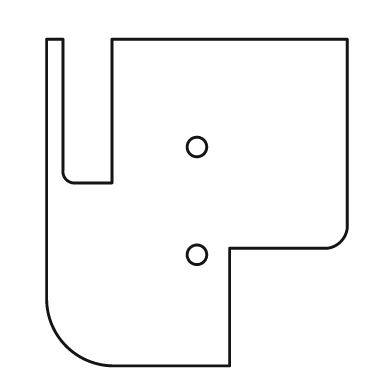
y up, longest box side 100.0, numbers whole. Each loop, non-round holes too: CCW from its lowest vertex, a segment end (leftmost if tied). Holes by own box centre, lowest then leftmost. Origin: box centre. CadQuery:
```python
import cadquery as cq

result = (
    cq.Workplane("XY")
    .moveTo(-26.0, -50.0)
    .lineTo(10.0, -50.0)
    .lineTo(10.0, -14.0)
    .lineTo(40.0, -14.0)
    .threePointArc((44.0, -12.0), (46.0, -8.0))
    .lineTo(46.0, 50.0)
    .lineTo(-26.0, 50.0)
    .lineTo(-26.0, 6.0)
    .lineTo(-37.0, 6.0)
    .threePointArc((-40.0, 7.0), (-41.0, 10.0))
    .lineTo(-41.0, 50.0)
    .lineTo(-46.0, 50.0)
    .lineTo(-46.0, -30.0)
    .threePointArc((-40.0, -44.0), (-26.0, -50.0))
    .close()
    .moveTo(0.0, -16.0)
    .circle(3.0)
    .moveTo(0.0, 17.0)
    .circle(3.0)
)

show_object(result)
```